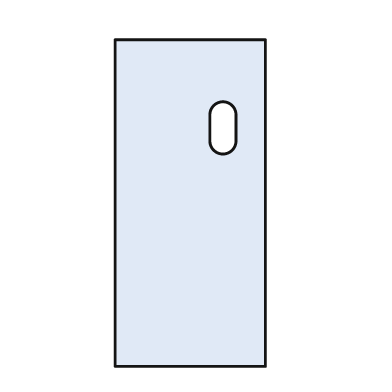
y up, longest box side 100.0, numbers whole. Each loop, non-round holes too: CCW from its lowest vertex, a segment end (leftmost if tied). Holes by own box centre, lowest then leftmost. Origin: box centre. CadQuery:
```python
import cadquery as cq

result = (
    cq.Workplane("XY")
    .moveTo(-23.0, -50.0)
    .lineTo(23.0, -50.0)
    .lineTo(23.0, 50.0)
    .lineTo(-23.0, 50.0)
    .close()
    .moveTo(6.0, 19.0)
    .threePointArc((10.0, 15.0), (14.0, 19.0))
    .lineTo(14.0, 27.0)
    .threePointArc((10.0, 31.0), (6.0, 27.0))
    .close()
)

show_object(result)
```